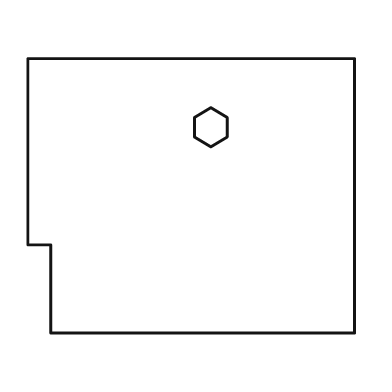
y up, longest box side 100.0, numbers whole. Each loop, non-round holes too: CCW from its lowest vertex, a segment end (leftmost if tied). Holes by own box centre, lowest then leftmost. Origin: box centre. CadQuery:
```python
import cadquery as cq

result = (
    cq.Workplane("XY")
    .moveTo(-43.0, -42.0)
    .lineTo(50.0, -42.0)
    .lineTo(50.0, 42.0)
    .lineTo(-50.0, 42.0)
    .lineTo(-50.0, -15.0)
    .lineTo(-43.0, -15.0)
    .close()
    .moveTo(6.0, 15.0)
    .lineTo(11.0, 18.0)
    .lineTo(11.0, 24.0)
    .lineTo(6.0, 27.0)
    .lineTo(1.0, 24.0)
    .lineTo(1.0, 18.0)
    .close()
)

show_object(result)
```